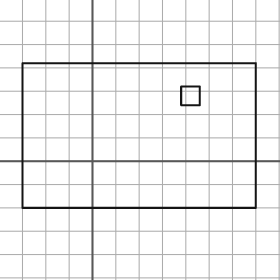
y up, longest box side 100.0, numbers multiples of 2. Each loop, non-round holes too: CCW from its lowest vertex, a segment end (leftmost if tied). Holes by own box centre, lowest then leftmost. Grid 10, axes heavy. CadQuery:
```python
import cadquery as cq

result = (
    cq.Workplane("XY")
    .moveTo(-30.0, -20.0)
    .lineTo(70.0, -20.0)
    .lineTo(70.0, 42.0)
    .lineTo(-30.0, 42.0)
    .close()
    .moveTo(38.0, 24.0)
    .lineTo(46.0, 24.0)
    .lineTo(46.0, 32.0)
    .lineTo(38.0, 32.0)
    .close()
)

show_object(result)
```